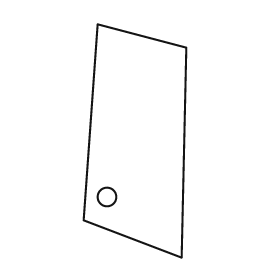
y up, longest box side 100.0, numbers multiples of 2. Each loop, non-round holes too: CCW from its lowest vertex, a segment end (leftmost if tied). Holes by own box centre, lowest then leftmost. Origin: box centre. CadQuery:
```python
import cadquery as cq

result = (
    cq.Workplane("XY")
    .moveTo(20.0, -50.0)
    .lineTo(22.0, 40.0)
    .lineTo(-16.0, 50.0)
    .lineTo(-22.0, -34.0)
    .close()
    .moveTo(-12.0, -24.0)
    .circle(4.0)
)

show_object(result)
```